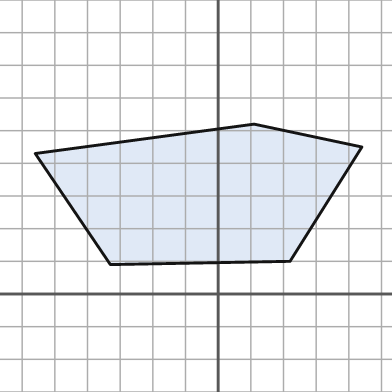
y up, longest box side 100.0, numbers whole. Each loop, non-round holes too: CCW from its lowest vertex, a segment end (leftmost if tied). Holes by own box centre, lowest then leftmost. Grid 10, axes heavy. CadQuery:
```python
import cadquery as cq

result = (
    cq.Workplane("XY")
    .moveTo(-33.0, 9.0)
    .lineTo(22.0, 10.0)
    .lineTo(44.0, 45.0)
    .lineTo(11.0, 52.0)
    .lineTo(-56.0, 43.0)
    .close()
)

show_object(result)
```